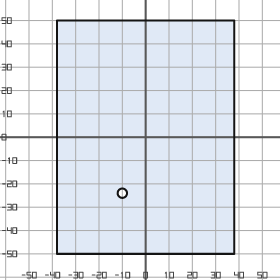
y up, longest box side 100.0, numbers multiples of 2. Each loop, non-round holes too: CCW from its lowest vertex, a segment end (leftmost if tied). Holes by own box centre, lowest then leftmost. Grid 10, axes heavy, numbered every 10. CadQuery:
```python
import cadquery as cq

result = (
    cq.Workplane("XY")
    .moveTo(-38.0, -50.0)
    .lineTo(38.0, -50.0)
    .lineTo(38.0, 50.0)
    .lineTo(-38.0, 50.0)
    .close()
    .moveTo(-10.0, -24.0)
    .circle(2.0)
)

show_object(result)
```